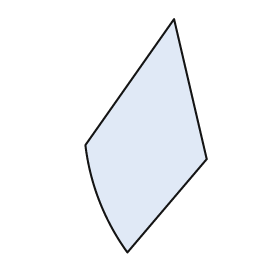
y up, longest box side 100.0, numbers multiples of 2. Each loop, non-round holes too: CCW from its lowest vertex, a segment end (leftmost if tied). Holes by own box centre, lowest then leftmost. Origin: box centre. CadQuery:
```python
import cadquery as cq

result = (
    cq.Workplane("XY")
    .moveTo(-8.0, -50.0)
    .lineTo(26.0, -10.0)
    .lineTo(12.0, 50.0)
    .lineTo(-26.0, -4.0)
    .threePointArc((-20.0, -28.0), (-8.0, -50.0))
    .close()
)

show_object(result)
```